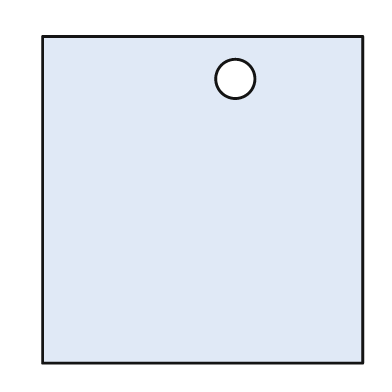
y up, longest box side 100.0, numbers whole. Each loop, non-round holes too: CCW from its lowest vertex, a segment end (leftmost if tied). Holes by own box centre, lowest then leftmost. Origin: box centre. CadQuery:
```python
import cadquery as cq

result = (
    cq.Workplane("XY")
    .moveTo(-49.0, -50.0)
    .lineTo(49.0, -50.0)
    .lineTo(49.0, 50.0)
    .lineTo(-49.0, 50.0)
    .close()
    .moveTo(10.0, 37.0)
    .circle(6.0)
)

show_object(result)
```